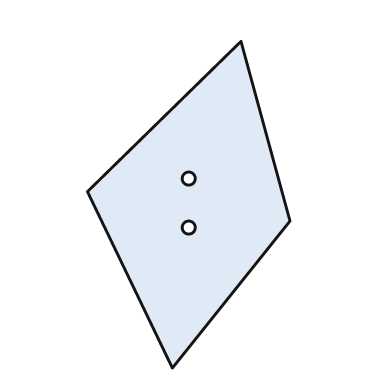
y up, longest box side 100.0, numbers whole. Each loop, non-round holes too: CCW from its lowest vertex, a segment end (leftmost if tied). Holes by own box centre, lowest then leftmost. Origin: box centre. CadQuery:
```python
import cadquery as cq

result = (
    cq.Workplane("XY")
    .moveTo(-5.0, -50.0)
    .lineTo(31.0, -5.0)
    .lineTo(16.0, 50.0)
    .lineTo(-31.0, 4.0)
    .close()
    .moveTo(0.0, -7.0)
    .circle(2.0)
    .moveTo(0.0, 8.0)
    .circle(2.0)
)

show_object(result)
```